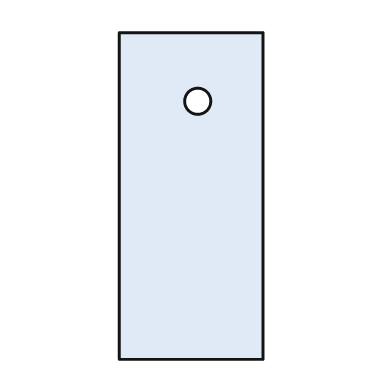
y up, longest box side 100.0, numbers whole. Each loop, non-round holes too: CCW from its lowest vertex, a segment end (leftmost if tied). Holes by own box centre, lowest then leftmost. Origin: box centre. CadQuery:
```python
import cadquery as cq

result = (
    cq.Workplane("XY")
    .moveTo(-22.0, -50.0)
    .lineTo(22.0, -50.0)
    .lineTo(22.0, 50.0)
    .lineTo(-22.0, 50.0)
    .close()
    .moveTo(2.0, 29.0)
    .circle(4.0)
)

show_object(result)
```